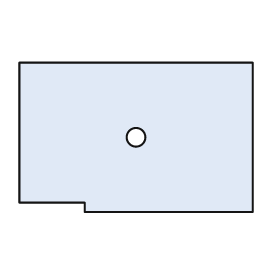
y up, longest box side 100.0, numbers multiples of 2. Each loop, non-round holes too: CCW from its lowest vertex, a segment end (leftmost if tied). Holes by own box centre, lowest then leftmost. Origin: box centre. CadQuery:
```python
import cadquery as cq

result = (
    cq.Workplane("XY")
    .moveTo(-22.0, -32.0)
    .lineTo(50.0, -32.0)
    .lineTo(50.0, 32.0)
    .lineTo(-50.0, 32.0)
    .lineTo(-50.0, -28.0)
    .lineTo(-22.0, -28.0)
    .close()
    .moveTo(0.0, 0.0)
    .circle(4.0)
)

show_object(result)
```